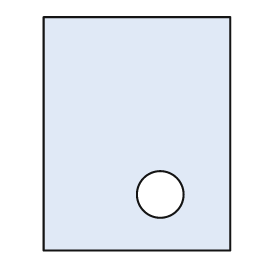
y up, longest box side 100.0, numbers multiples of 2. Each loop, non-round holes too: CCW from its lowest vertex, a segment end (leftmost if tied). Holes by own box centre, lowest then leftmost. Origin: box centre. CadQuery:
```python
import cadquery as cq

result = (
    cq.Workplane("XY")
    .moveTo(-40.0, -50.0)
    .lineTo(40.0, -50.0)
    .lineTo(40.0, 50.0)
    .lineTo(-40.0, 50.0)
    .close()
    .moveTo(10.0, -26.0)
    .circle(10.0)
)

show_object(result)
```